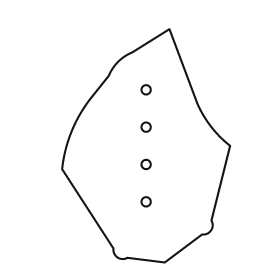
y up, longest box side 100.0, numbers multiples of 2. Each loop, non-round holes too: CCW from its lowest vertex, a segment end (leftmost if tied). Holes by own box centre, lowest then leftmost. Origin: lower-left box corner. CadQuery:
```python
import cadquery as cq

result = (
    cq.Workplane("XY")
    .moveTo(44.0, 0.0)
    .lineTo(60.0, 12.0)
    .threePointArc((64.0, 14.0), (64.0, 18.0))
    .lineTo(72.0, 50.0)
    .threePointArc((64.0, 58.0), (58.0, 68.0))
    .lineTo(46.0, 100.0)
    .lineTo(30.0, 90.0)
    .threePointArc((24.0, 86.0), (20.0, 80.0))
    .lineTo(12.0, 70.0)
    .threePointArc((4.0, 56.0), (0.0, 40.0))
    .lineTo(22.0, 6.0)
    .threePointArc((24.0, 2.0), (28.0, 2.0))
    .close()
    .moveTo(36.0, 26.0)
    .circle(2.0)
    .moveTo(36.0, 42.0)
    .circle(2.0)
    .moveTo(36.0, 58.0)
    .circle(2.0)
    .moveTo(36.0, 74.0)
    .circle(2.0)
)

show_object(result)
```